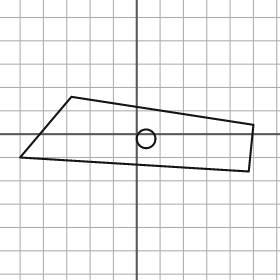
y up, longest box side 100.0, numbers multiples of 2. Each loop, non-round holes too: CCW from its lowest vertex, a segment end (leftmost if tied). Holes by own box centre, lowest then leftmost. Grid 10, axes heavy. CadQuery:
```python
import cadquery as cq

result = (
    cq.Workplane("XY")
    .moveTo(48.0, -16.0)
    .lineTo(50.0, 4.0)
    .lineTo(-28.0, 16.0)
    .lineTo(-50.0, -10.0)
    .close()
    .moveTo(4.0, -2.0)
    .circle(4.0)
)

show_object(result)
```